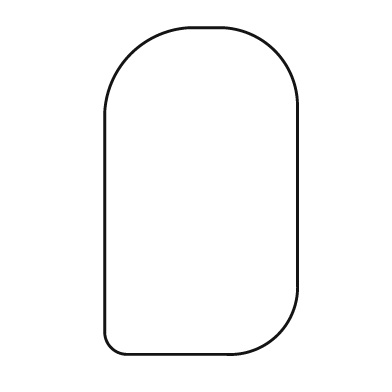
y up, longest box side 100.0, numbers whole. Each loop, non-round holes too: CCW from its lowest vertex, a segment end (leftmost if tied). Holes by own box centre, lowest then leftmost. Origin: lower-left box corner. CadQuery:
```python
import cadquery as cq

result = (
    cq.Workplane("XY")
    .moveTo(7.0, 0.0)
    .lineTo(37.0, 0.0)
    .threePointArc((53.0, 6.0), (59.0, 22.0))
    .lineTo(59.0, 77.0)
    .threePointArc((52.0, 93.0), (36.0, 100.0))
    .lineTo(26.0, 100.0)
    .threePointArc((8.0, 92.0), (0.0, 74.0))
    .lineTo(0.0, 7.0)
    .threePointArc((2.0, 2.0), (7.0, 0.0))
    .close()
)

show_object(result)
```